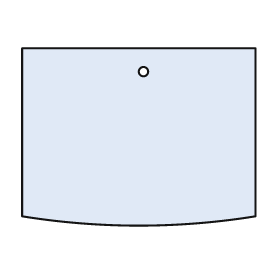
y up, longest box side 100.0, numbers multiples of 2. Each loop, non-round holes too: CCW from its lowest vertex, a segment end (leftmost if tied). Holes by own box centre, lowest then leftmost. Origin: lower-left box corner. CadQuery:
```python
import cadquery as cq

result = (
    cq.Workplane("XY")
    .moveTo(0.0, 4.0)
    .threePointArc((50.0, 0.0), (100.0, 4.0))
    .lineTo(100.0, 76.0)
    .lineTo(0.0, 76.0)
    .close()
    .moveTo(52.0, 66.0)
    .circle(2.0)
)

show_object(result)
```